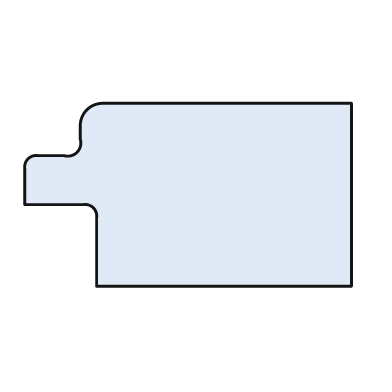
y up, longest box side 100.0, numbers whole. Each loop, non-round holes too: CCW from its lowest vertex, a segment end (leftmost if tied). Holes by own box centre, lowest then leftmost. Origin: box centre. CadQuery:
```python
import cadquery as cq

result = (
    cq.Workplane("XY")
    .moveTo(-28.0, -28.0)
    .lineTo(50.0, -28.0)
    .lineTo(50.0, 28.0)
    .lineTo(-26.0, 28.0)
    .threePointArc((-31.0, 26.0), (-33.0, 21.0))
    .lineTo(-33.0, 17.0)
    .threePointArc((-34.0, 13.0), (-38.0, 12.0))
    .lineTo(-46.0, 12.0)
    .threePointArc((-49.0, 11.0), (-50.0, 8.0))
    .lineTo(-50.0, -3.0)
    .lineTo(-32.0, -3.0)
    .threePointArc((-29.0, -4.0), (-28.0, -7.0))
    .close()
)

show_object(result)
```